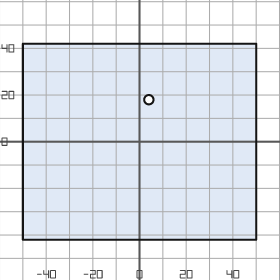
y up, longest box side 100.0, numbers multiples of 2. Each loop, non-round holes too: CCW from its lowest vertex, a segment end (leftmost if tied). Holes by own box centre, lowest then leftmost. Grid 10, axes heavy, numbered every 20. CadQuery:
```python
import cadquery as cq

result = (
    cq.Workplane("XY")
    .moveTo(-50.0, -42.0)
    .lineTo(50.0, -42.0)
    .lineTo(50.0, 42.0)
    .lineTo(-50.0, 42.0)
    .close()
    .moveTo(4.0, 18.0)
    .circle(2.0)
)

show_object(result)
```